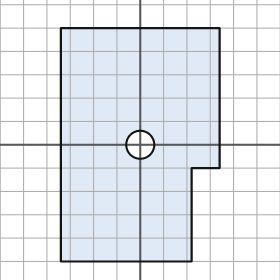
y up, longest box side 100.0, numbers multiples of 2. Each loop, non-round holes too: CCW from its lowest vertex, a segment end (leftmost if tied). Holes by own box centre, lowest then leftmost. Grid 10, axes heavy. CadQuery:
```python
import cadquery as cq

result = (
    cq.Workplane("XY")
    .moveTo(-34.0, -50.0)
    .lineTo(22.0, -50.0)
    .lineTo(22.0, -10.0)
    .lineTo(34.0, -10.0)
    .lineTo(34.0, 50.0)
    .lineTo(-34.0, 50.0)
    .close()
    .moveTo(0.0, 0.0)
    .circle(6.0)
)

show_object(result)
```